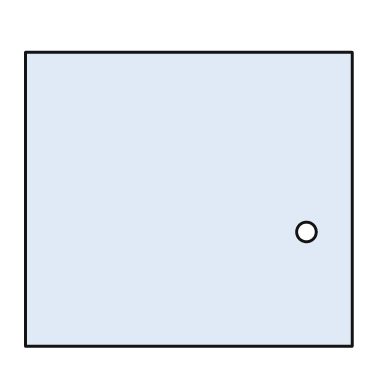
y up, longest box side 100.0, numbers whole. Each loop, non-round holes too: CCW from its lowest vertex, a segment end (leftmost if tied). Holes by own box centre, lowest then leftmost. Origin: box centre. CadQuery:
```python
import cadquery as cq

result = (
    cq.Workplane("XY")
    .moveTo(-50.0, -45.0)
    .lineTo(50.0, -45.0)
    .lineTo(50.0, 45.0)
    .lineTo(-50.0, 45.0)
    .close()
    .moveTo(36.0, -10.0)
    .circle(3.0)
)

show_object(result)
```